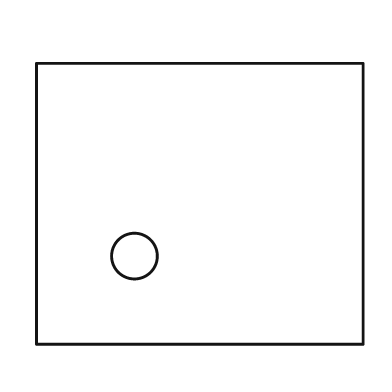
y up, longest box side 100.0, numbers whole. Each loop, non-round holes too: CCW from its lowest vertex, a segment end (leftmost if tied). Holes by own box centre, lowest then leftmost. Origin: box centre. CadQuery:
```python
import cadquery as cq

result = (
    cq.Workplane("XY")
    .moveTo(-50.0, -43.0)
    .lineTo(50.0, -43.0)
    .lineTo(50.0, 43.0)
    .lineTo(-50.0, 43.0)
    .close()
    .moveTo(-20.0, -16.0)
    .circle(7.0)
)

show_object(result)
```